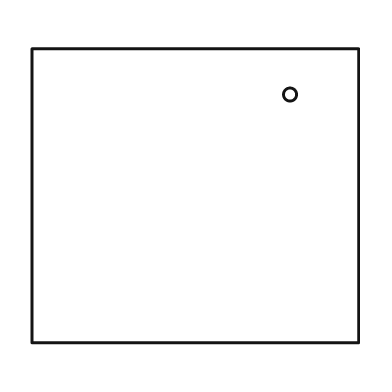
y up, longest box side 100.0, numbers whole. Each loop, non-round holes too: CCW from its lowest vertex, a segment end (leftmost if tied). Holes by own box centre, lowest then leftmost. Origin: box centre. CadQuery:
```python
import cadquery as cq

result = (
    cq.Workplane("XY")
    .moveTo(-50.0, -45.0)
    .lineTo(50.0, -45.0)
    .lineTo(50.0, 45.0)
    .lineTo(-50.0, 45.0)
    .close()
    .moveTo(29.0, 31.0)
    .circle(2.0)
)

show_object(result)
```